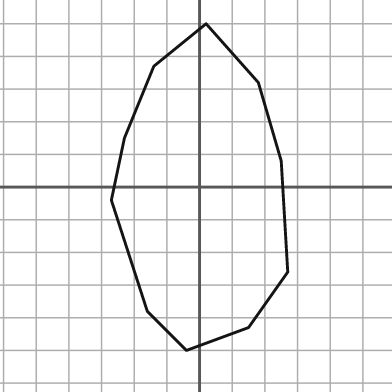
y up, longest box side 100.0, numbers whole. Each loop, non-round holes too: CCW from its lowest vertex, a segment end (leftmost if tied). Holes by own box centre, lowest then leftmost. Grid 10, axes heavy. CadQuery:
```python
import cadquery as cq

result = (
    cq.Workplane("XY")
    .moveTo(-4.0, -50.0)
    .lineTo(15.0, -43.0)
    .lineTo(27.0, -26.0)
    .lineTo(25.0, 8.0)
    .lineTo(18.0, 32.0)
    .lineTo(2.0, 50.0)
    .lineTo(-14.0, 37.0)
    .lineTo(-23.0, 15.0)
    .lineTo(-27.0, -4.0)
    .lineTo(-16.0, -38.0)
    .close()
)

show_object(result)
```